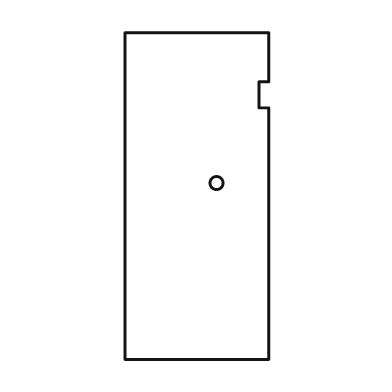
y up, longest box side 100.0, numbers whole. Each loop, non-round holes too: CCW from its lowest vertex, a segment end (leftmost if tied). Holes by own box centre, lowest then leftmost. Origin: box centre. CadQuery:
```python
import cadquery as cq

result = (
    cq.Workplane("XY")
    .moveTo(-22.0, -50.0)
    .lineTo(22.0, -50.0)
    .lineTo(22.0, 27.0)
    .lineTo(19.0, 27.0)
    .lineTo(19.0, 35.0)
    .lineTo(22.0, 35.0)
    .lineTo(22.0, 50.0)
    .lineTo(-22.0, 50.0)
    .close()
    .moveTo(6.0, 4.0)
    .circle(2.0)
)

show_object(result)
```